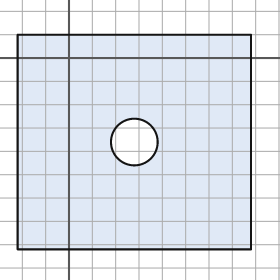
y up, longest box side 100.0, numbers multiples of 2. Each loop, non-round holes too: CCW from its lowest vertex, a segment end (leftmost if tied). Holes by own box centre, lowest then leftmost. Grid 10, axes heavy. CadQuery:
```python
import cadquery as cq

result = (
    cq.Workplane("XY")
    .moveTo(-22.0, -82.0)
    .lineTo(78.0, -82.0)
    .lineTo(78.0, 10.0)
    .lineTo(-22.0, 10.0)
    .close()
    .moveTo(28.0, -36.0)
    .circle(10.0)
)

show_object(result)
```